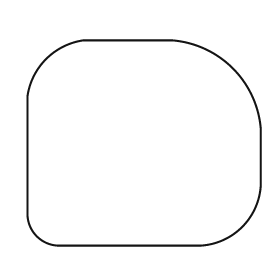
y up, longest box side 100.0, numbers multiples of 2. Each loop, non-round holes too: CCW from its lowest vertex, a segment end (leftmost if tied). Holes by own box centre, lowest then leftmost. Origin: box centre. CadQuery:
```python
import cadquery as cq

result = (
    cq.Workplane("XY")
    .moveTo(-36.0, -44.0)
    .lineTo(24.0, -44.0)
    .threePointArc((42.0, -36.0), (50.0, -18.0))
    .lineTo(50.0, 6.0)
    .threePointArc((38.0, 32.0), (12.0, 44.0))
    .lineTo(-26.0, 44.0)
    .threePointArc((-42.0, 36.0), (-50.0, 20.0))
    .lineTo(-50.0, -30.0)
    .threePointArc((-46.0, -40.0), (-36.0, -44.0))
    .close()
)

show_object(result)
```